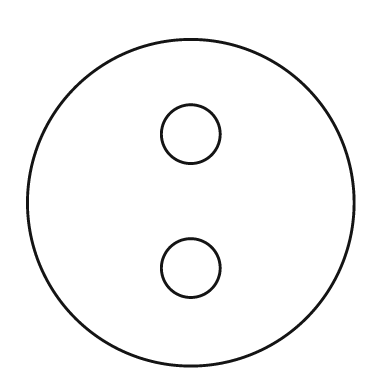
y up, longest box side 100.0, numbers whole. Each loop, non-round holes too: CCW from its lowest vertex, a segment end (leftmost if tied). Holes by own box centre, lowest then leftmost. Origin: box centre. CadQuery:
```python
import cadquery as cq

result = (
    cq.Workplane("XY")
    .moveTo(0.0, 0.0)
    .circle(50.0)
    .moveTo(0.0, -20.0)
    .circle(9.0)
    .moveTo(0.0, 21.0)
    .circle(9.0)
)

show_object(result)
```